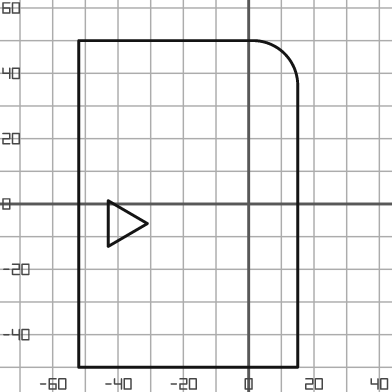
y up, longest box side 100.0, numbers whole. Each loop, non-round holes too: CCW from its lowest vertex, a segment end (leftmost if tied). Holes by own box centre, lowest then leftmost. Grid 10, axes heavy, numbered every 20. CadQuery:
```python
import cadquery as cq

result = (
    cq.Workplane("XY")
    .moveTo(-52.0, -50.0)
    .lineTo(15.0, -50.0)
    .lineTo(15.0, 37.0)
    .threePointArc((11.0, 46.0), (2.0, 50.0))
    .lineTo(-52.0, 50.0)
    .close()
    .moveTo(-43.0, -13.0)
    .lineTo(-31.0, -6.0)
    .lineTo(-43.0, 1.0)
    .close()
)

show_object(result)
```